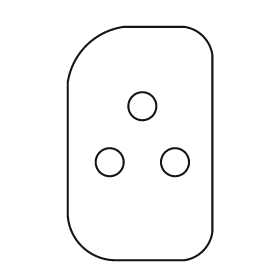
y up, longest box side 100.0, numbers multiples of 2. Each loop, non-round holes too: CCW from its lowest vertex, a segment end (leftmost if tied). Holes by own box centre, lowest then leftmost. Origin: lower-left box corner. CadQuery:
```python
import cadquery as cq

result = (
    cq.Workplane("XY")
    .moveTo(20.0, 0.0)
    .lineTo(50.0, 0.0)
    .threePointArc((58.0, 4.0), (62.0, 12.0))
    .lineTo(62.0, 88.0)
    .threePointArc((58.0, 96.0), (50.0, 100.0))
    .lineTo(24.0, 100.0)
    .threePointArc((8.0, 92.0), (0.0, 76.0))
    .lineTo(0.0, 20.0)
    .threePointArc((6.0, 6.0), (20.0, 0.0))
    .close()
    .moveTo(18.0, 42.0)
    .circle(6.0)
    .moveTo(46.0, 42.0)
    .circle(6.0)
    .moveTo(32.0, 66.0)
    .circle(6.0)
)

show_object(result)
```